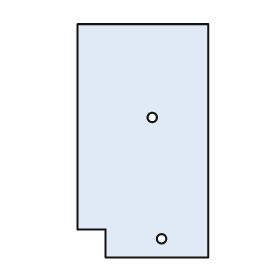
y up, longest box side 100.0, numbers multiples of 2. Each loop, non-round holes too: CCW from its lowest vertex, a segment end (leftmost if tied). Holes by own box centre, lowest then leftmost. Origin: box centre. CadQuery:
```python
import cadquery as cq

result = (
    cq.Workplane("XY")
    .moveTo(-16.0, -50.0)
    .lineTo(28.0, -50.0)
    .lineTo(28.0, 50.0)
    .lineTo(-28.0, 50.0)
    .lineTo(-28.0, -38.0)
    .lineTo(-16.0, -38.0)
    .close()
    .moveTo(8.0, -42.0)
    .circle(2.0)
    .moveTo(4.0, 10.0)
    .circle(2.0)
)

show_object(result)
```